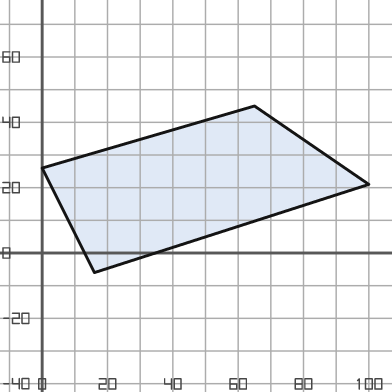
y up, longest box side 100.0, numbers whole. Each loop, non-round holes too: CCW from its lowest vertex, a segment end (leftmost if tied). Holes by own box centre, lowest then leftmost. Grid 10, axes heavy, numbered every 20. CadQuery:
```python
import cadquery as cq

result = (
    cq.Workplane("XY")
    .moveTo(16.0, -6.0)
    .lineTo(100.0, 21.0)
    .lineTo(65.0, 45.0)
    .lineTo(0.0, 26.0)
    .close()
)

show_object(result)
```